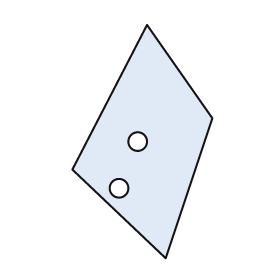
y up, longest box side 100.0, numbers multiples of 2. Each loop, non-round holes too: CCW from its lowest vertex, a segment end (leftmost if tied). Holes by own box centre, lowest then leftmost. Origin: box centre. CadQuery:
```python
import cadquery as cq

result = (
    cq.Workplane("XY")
    .moveTo(10.0, -50.0)
    .lineTo(30.0, 10.0)
    .lineTo(2.0, 50.0)
    .lineTo(-30.0, -12.0)
    .close()
    .moveTo(-10.0, -20.0)
    .circle(4.0)
    .moveTo(-2.0, 0.0)
    .circle(4.0)
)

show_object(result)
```